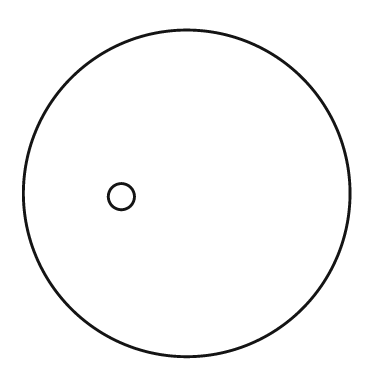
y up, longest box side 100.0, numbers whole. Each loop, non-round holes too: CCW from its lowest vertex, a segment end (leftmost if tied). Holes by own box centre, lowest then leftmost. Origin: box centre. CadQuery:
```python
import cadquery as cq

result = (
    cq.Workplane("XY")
    .moveTo(0.0, 0.0)
    .circle(50.0)
    .moveTo(-20.0, -1.0)
    .circle(4.0)
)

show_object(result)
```